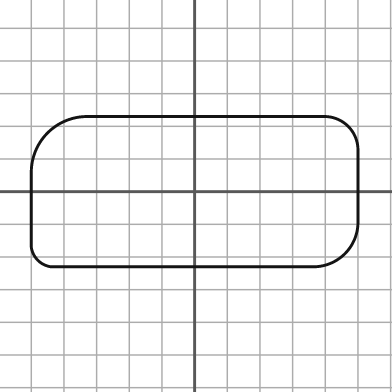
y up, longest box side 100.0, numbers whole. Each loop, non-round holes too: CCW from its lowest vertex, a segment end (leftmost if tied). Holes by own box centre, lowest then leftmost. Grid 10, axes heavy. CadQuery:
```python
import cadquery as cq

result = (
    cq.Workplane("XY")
    .moveTo(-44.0, -23.0)
    .lineTo(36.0, -23.0)
    .threePointArc((46.0, -19.0), (50.0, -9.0))
    .lineTo(50.0, 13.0)
    .threePointArc((47.0, 20.0), (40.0, 23.0))
    .lineTo(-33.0, 23.0)
    .threePointArc((-45.0, 18.0), (-50.0, 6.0))
    .lineTo(-50.0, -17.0)
    .threePointArc((-48.0, -21.0), (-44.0, -23.0))
    .close()
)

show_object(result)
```